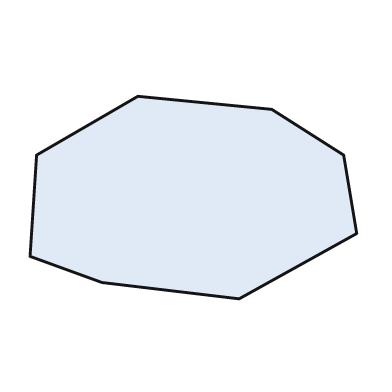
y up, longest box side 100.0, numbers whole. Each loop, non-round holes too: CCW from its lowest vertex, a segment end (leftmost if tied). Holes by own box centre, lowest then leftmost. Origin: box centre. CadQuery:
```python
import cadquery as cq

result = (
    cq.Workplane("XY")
    .moveTo(14.0, -31.0)
    .lineTo(50.0, -11.0)
    .lineTo(46.0, 13.0)
    .lineTo(24.0, 27.0)
    .lineTo(-17.0, 31.0)
    .lineTo(-48.0, 13.0)
    .lineTo(-50.0, -18.0)
    .lineTo(-28.0, -26.0)
    .close()
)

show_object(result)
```